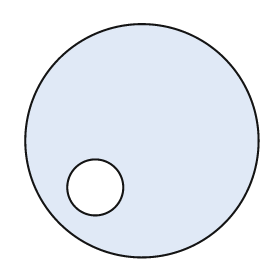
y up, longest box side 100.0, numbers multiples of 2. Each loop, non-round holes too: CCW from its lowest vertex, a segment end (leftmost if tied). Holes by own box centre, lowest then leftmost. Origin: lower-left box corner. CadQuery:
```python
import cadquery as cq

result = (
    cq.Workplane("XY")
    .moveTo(50.0, 50.0)
    .circle(50.0)
    .moveTo(30.0, 30.0)
    .circle(12.0)
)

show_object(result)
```